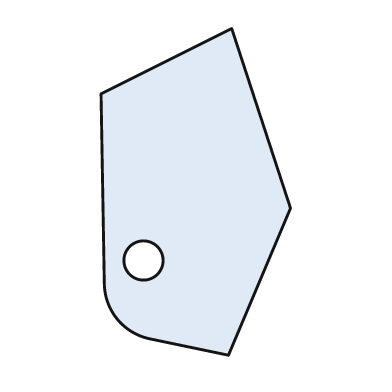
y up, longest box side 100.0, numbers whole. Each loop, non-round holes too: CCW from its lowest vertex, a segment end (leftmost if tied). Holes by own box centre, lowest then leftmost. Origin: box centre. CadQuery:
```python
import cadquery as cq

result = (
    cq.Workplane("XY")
    .moveTo(10.0, -50.0)
    .lineTo(29.0, -5.0)
    .lineTo(11.0, 50.0)
    .lineTo(-29.0, 30.0)
    .lineTo(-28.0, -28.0)
    .threePointArc((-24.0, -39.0), (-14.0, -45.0))
    .close()
    .moveTo(-16.0, -21.0)
    .circle(6.0)
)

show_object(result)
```